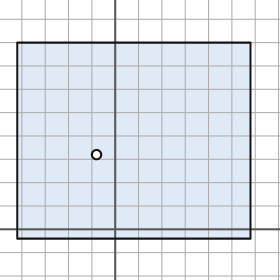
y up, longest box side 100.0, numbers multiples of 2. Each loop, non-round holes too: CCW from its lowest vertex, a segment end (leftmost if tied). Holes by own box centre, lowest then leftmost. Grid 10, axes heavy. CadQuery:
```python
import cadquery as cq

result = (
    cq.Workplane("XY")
    .moveTo(-42.0, -4.0)
    .lineTo(58.0, -4.0)
    .lineTo(58.0, 80.0)
    .lineTo(-42.0, 80.0)
    .close()
    .moveTo(-8.0, 32.0)
    .circle(2.0)
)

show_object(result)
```